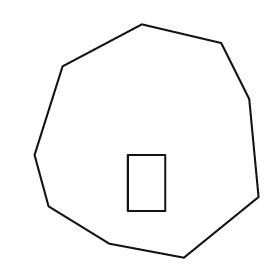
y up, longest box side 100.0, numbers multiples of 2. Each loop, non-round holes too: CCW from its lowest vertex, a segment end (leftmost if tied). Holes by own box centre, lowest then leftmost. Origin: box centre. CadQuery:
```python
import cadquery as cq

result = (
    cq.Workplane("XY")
    .moveTo(16.0, -50.0)
    .lineTo(48.0, -24.0)
    .lineTo(44.0, 18.0)
    .lineTo(32.0, 42.0)
    .lineTo(-2.0, 50.0)
    .lineTo(-36.0, 32.0)
    .lineTo(-48.0, -6.0)
    .lineTo(-42.0, -28.0)
    .lineTo(-16.0, -44.0)
    .close()
    .moveTo(-8.0, -30.0)
    .lineTo(8.0, -30.0)
    .lineTo(8.0, -6.0)
    .lineTo(-8.0, -6.0)
    .close()
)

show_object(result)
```